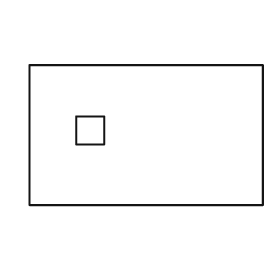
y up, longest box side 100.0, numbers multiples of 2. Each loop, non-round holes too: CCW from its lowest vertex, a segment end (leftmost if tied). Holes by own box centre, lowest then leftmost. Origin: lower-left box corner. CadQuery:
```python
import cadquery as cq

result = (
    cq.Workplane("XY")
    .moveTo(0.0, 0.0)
    .lineTo(100.0, 0.0)
    .lineTo(100.0, 60.0)
    .lineTo(0.0, 60.0)
    .close()
    .moveTo(20.0, 26.0)
    .lineTo(32.0, 26.0)
    .lineTo(32.0, 38.0)
    .lineTo(20.0, 38.0)
    .close()
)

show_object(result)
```